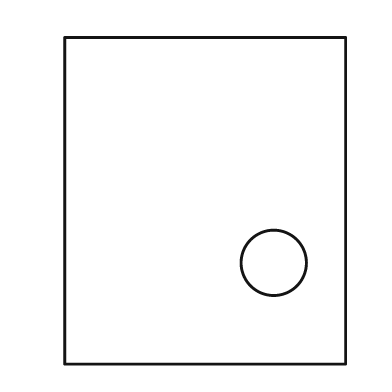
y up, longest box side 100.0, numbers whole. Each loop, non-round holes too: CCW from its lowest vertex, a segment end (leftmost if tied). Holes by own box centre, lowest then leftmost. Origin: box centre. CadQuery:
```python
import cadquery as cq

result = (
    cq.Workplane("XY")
    .moveTo(-43.0, -50.0)
    .lineTo(43.0, -50.0)
    .lineTo(43.0, 50.0)
    .lineTo(-43.0, 50.0)
    .close()
    .moveTo(21.0, -19.0)
    .circle(10.0)
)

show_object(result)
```